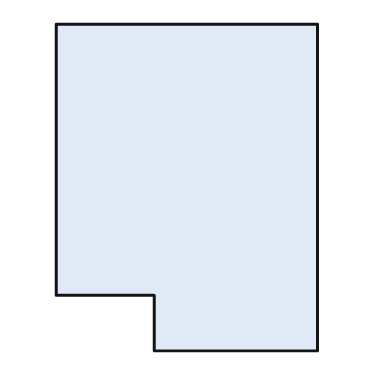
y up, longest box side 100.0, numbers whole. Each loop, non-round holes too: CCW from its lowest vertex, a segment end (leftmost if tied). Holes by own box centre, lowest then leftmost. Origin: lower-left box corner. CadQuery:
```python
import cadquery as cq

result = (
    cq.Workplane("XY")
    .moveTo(30.0, 0.0)
    .lineTo(80.0, 0.0)
    .lineTo(80.0, 100.0)
    .lineTo(0.0, 100.0)
    .lineTo(0.0, 17.0)
    .lineTo(30.0, 17.0)
    .close()
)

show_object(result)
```